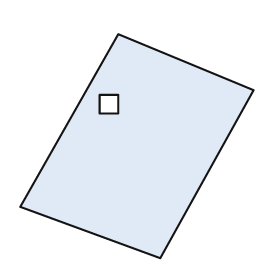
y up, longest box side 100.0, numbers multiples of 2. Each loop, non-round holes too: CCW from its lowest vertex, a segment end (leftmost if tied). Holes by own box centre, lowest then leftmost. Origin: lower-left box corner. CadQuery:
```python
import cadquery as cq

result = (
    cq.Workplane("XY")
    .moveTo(60.0, 0.0)
    .lineTo(100.0, 72.0)
    .lineTo(42.0, 96.0)
    .lineTo(0.0, 22.0)
    .close()
    .moveTo(34.0, 62.0)
    .lineTo(42.0, 62.0)
    .lineTo(42.0, 70.0)
    .lineTo(34.0, 70.0)
    .close()
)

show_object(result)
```